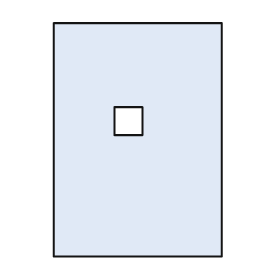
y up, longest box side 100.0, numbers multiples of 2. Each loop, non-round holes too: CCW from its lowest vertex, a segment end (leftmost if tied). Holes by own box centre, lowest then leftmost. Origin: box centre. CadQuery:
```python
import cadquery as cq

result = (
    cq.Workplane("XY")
    .moveTo(-36.0, -50.0)
    .lineTo(36.0, -50.0)
    .lineTo(36.0, 50.0)
    .lineTo(-36.0, 50.0)
    .close()
    .moveTo(-10.0, 2.0)
    .lineTo(2.0, 2.0)
    .lineTo(2.0, 14.0)
    .lineTo(-10.0, 14.0)
    .close()
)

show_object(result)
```